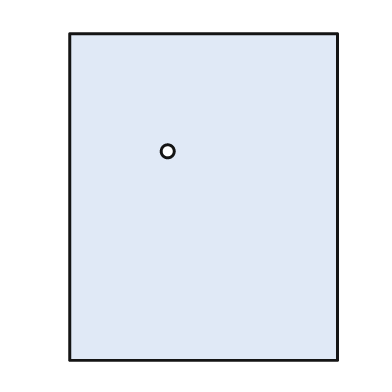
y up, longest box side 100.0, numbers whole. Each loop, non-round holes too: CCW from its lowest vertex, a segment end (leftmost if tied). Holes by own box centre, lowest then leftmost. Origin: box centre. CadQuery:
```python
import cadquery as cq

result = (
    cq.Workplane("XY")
    .moveTo(-41.0, -50.0)
    .lineTo(41.0, -50.0)
    .lineTo(41.0, 50.0)
    .lineTo(-41.0, 50.0)
    .close()
    .moveTo(-11.0, 14.0)
    .circle(2.0)
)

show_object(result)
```